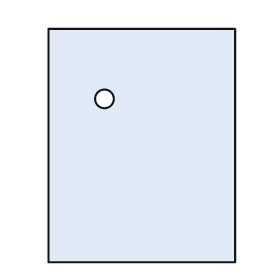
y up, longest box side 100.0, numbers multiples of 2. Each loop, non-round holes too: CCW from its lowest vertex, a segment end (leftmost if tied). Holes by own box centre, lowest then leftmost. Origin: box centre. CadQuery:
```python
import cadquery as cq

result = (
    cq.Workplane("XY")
    .moveTo(-40.0, -50.0)
    .lineTo(40.0, -50.0)
    .lineTo(40.0, 50.0)
    .lineTo(-40.0, 50.0)
    .close()
    .moveTo(-16.0, 20.0)
    .circle(4.0)
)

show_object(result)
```